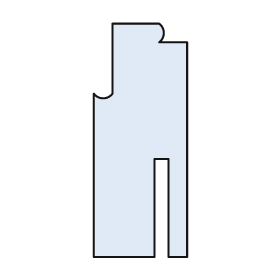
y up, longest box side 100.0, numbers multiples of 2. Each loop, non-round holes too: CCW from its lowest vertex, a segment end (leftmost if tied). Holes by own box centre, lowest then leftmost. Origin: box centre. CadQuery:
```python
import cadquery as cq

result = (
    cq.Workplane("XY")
    .moveTo(-20.0, -50.0)
    .lineTo(6.0, -50.0)
    .lineTo(6.0, -8.0)
    .lineTo(12.0, -8.0)
    .lineTo(12.0, -50.0)
    .lineTo(20.0, -50.0)
    .lineTo(20.0, 42.0)
    .lineTo(8.0, 42.0)
    .threePointArc((10.0, 46.0), (8.0, 50.0))
    .lineTo(-12.0, 50.0)
    .lineTo(-12.0, 20.0)
    .threePointArc((-16.0, 18.0), (-20.0, 20.0))
    .close()
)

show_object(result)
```